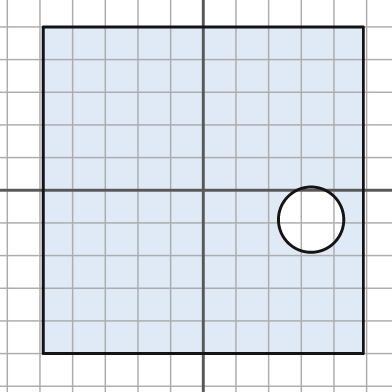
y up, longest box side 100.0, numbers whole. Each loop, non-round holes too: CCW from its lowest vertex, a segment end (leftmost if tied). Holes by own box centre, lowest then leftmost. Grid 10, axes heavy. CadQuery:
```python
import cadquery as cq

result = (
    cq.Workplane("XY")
    .moveTo(-49.0, -50.0)
    .lineTo(49.0, -50.0)
    .lineTo(49.0, 50.0)
    .lineTo(-49.0, 50.0)
    .close()
    .moveTo(33.0, -9.0)
    .circle(10.0)
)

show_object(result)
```